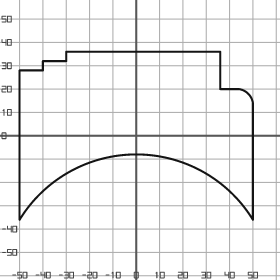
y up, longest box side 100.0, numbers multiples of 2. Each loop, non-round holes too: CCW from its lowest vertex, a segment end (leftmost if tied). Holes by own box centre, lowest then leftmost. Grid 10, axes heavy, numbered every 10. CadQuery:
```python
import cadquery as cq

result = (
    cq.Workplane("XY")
    .moveTo(-50.0, -36.0)
    .threePointArc((0.0, -8.0), (50.0, -36.0))
    .lineTo(50.0, 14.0)
    .threePointArc((48.0, 18.0), (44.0, 20.0))
    .lineTo(36.0, 20.0)
    .lineTo(36.0, 36.0)
    .lineTo(-30.0, 36.0)
    .lineTo(-30.0, 32.0)
    .lineTo(-40.0, 32.0)
    .lineTo(-40.0, 28.0)
    .lineTo(-50.0, 28.0)
    .close()
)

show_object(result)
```